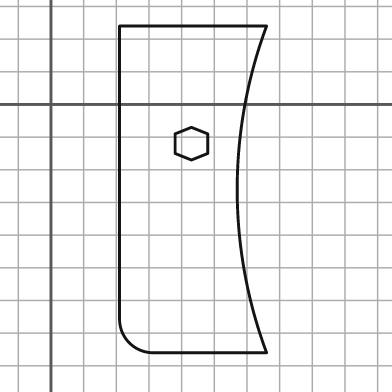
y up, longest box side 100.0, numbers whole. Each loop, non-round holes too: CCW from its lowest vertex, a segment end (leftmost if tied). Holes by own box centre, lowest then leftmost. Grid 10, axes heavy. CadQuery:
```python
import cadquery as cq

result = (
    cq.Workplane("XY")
    .moveTo(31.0, -76.0)
    .lineTo(66.0, -76.0)
    .threePointArc((57.0, -26.0), (66.0, 24.0))
    .lineTo(21.0, 24.0)
    .lineTo(21.0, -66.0)
    .threePointArc((24.0, -73.0), (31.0, -76.0))
    .close()
    .moveTo(43.0, -17.0)
    .lineTo(48.0, -15.0)
    .lineTo(48.0, -9.0)
    .lineTo(43.0, -7.0)
    .lineTo(38.0, -9.0)
    .lineTo(38.0, -15.0)
    .close()
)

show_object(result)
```